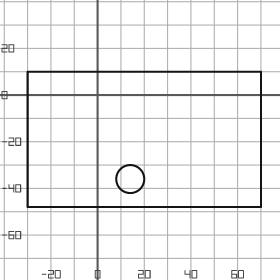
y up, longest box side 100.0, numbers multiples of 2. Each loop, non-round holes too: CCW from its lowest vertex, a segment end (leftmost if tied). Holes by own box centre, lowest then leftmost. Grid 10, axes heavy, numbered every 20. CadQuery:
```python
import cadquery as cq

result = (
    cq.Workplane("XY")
    .moveTo(-30.0, -48.0)
    .lineTo(70.0, -48.0)
    .lineTo(70.0, 10.0)
    .lineTo(-30.0, 10.0)
    .close()
    .moveTo(14.0, -36.0)
    .circle(6.0)
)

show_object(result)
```